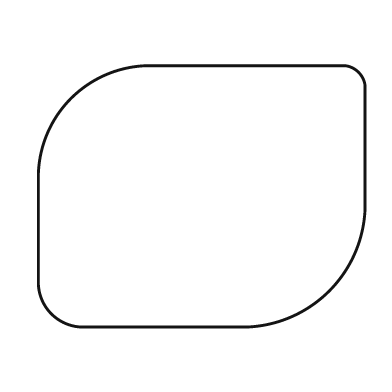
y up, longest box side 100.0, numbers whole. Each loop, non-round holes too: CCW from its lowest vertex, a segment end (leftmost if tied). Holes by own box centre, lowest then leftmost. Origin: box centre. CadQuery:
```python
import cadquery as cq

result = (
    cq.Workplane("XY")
    .moveTo(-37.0, -40.0)
    .lineTo(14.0, -40.0)
    .threePointArc((39.0, -29.0), (50.0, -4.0))
    .lineTo(50.0, 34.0)
    .threePointArc((48.0, 38.0), (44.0, 40.0))
    .lineTo(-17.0, 40.0)
    .threePointArc((-40.0, 30.0), (-50.0, 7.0))
    .lineTo(-50.0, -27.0)
    .threePointArc((-46.0, -36.0), (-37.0, -40.0))
    .close()
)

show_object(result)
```